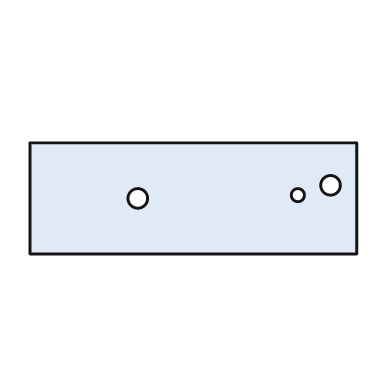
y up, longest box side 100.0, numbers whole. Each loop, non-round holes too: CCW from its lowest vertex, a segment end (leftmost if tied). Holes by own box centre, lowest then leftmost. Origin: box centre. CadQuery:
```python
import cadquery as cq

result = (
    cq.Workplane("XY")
    .moveTo(-50.0, -17.0)
    .lineTo(50.0, -17.0)
    .lineTo(50.0, 17.0)
    .lineTo(-50.0, 17.0)
    .close()
    .moveTo(-17.0, 0.0)
    .circle(3.0)
    .moveTo(32.0, 1.0)
    .circle(2.0)
    .moveTo(42.0, 4.0)
    .circle(3.0)
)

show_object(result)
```